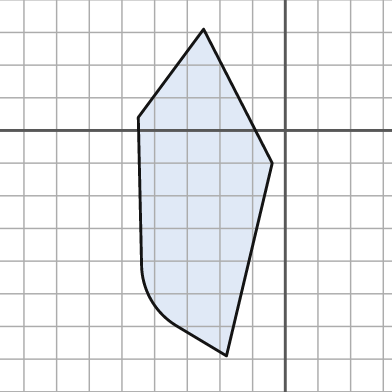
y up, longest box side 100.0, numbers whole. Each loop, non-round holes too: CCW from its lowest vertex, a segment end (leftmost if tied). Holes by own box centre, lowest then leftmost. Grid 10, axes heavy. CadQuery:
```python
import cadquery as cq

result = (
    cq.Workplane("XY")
    .moveTo(-18.0, -69.0)
    .lineTo(-4.0, -10.0)
    .lineTo(-25.0, 31.0)
    .lineTo(-45.0, 4.0)
    .lineTo(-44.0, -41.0)
    .threePointArc((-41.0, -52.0), (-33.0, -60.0))
    .close()
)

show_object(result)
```